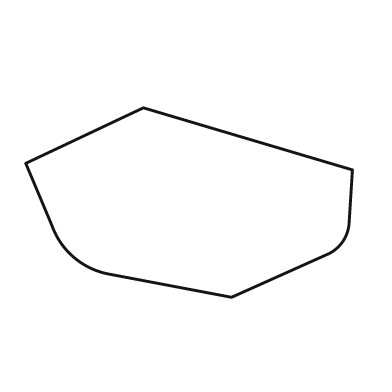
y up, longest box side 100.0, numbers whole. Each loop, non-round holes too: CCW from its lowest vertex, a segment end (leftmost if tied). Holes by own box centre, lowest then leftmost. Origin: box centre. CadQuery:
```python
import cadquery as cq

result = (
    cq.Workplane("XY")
    .moveTo(13.0, -29.0)
    .lineTo(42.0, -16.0)
    .threePointArc((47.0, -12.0), (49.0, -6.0))
    .lineTo(50.0, 10.0)
    .lineTo(-14.0, 29.0)
    .lineTo(-50.0, 12.0)
    .lineTo(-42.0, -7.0)
    .threePointArc((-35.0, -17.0), (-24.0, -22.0))
    .close()
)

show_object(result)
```